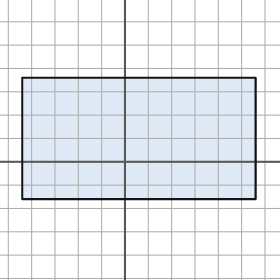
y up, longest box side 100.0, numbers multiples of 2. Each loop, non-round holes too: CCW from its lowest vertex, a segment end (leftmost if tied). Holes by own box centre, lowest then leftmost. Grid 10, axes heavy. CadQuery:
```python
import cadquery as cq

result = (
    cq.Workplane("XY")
    .moveTo(-44.0, -16.0)
    .lineTo(56.0, -16.0)
    .lineTo(56.0, 36.0)
    .lineTo(-44.0, 36.0)
    .close()
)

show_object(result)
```